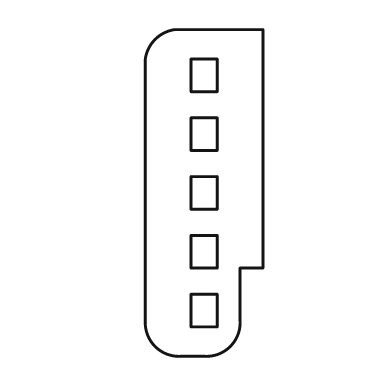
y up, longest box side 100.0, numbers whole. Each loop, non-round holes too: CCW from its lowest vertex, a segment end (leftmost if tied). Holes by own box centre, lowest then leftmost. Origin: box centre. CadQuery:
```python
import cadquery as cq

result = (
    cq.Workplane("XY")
    .moveTo(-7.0, -50.0)
    .lineTo(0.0, -50.0)
    .threePointArc((8.0, -47.0), (11.0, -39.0))
    .lineTo(11.0, -23.0)
    .lineTo(18.0, -23.0)
    .lineTo(18.0, 50.0)
    .lineTo(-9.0, 50.0)
    .threePointArc((-15.0, 47.0), (-18.0, 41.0))
    .lineTo(-18.0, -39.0)
    .threePointArc((-15.0, -47.0), (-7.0, -50.0))
    .close()
    .moveTo(-4.0, -41.0)
    .lineTo(4.0, -41.0)
    .lineTo(4.0, -31.0)
    .lineTo(-4.0, -31.0)
    .close()
    .moveTo(-4.0, -23.0)
    .lineTo(4.0, -23.0)
    .lineTo(4.0, -13.0)
    .lineTo(-4.0, -13.0)
    .close()
    .moveTo(-4.0, -5.0)
    .lineTo(4.0, -5.0)
    .lineTo(4.0, 5.0)
    .lineTo(-4.0, 5.0)
    .close()
    .moveTo(-4.0, 13.0)
    .lineTo(4.0, 13.0)
    .lineTo(4.0, 23.0)
    .lineTo(-4.0, 23.0)
    .close()
    .moveTo(-4.0, 31.0)
    .lineTo(4.0, 31.0)
    .lineTo(4.0, 41.0)
    .lineTo(-4.0, 41.0)
    .close()
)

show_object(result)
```